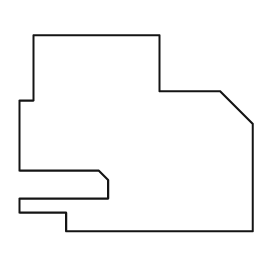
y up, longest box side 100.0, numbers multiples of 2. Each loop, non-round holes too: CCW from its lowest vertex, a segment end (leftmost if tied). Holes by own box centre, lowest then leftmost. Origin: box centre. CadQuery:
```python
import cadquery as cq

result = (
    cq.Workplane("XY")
    .moveTo(-30.0, -42.0)
    .lineTo(50.0, -42.0)
    .lineTo(50.0, 4.0)
    .lineTo(36.0, 18.0)
    .lineTo(10.0, 18.0)
    .lineTo(10.0, 42.0)
    .lineTo(-44.0, 42.0)
    .lineTo(-44.0, 14.0)
    .lineTo(-50.0, 14.0)
    .lineTo(-50.0, -16.0)
    .lineTo(-16.0, -16.0)
    .lineTo(-12.0, -20.0)
    .lineTo(-12.0, -28.0)
    .lineTo(-50.0, -28.0)
    .lineTo(-50.0, -34.0)
    .lineTo(-30.0, -34.0)
    .close()
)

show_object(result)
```